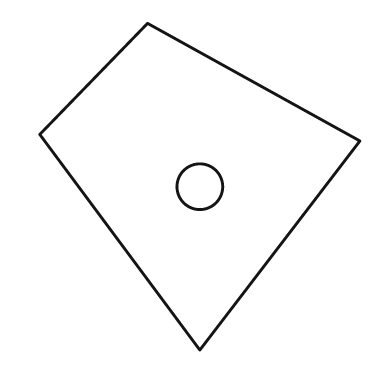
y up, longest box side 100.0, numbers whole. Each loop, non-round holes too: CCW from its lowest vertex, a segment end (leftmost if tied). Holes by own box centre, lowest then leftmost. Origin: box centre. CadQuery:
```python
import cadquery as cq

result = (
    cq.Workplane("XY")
    .moveTo(0.0, -50.0)
    .lineTo(49.0, 14.0)
    .lineTo(-16.0, 50.0)
    .lineTo(-49.0, 16.0)
    .close()
    .moveTo(0.0, 0.0)
    .circle(7.0)
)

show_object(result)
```